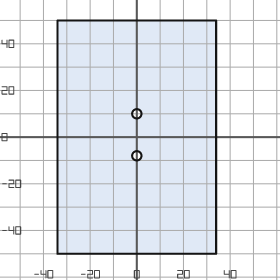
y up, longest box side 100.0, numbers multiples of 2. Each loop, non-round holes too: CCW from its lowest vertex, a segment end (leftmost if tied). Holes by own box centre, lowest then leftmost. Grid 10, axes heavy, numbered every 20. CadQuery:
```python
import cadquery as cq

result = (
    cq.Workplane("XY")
    .moveTo(-34.0, -50.0)
    .lineTo(34.0, -50.0)
    .lineTo(34.0, 50.0)
    .lineTo(-34.0, 50.0)
    .close()
    .moveTo(0.0, -8.0)
    .circle(2.0)
    .moveTo(0.0, 10.0)
    .circle(2.0)
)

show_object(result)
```